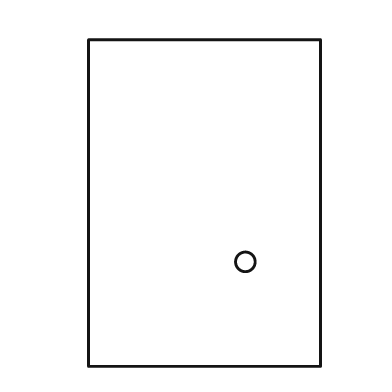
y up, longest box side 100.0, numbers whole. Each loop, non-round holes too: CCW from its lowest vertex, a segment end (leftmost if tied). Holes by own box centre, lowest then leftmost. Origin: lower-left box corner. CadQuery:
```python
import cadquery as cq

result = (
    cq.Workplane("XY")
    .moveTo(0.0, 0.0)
    .lineTo(71.0, 0.0)
    .lineTo(71.0, 100.0)
    .lineTo(0.0, 100.0)
    .close()
    .moveTo(48.0, 32.0)
    .circle(3.0)
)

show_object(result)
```